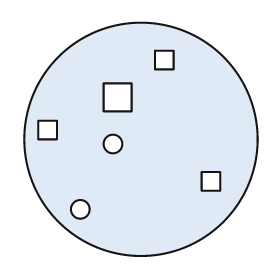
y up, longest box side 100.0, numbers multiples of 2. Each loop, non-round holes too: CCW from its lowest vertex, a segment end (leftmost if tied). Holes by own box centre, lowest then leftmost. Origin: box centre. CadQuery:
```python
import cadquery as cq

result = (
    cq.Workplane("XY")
    .moveTo(0.0, 0.0)
    .circle(50.0)
    .moveTo(-26.0, -30.0)
    .circle(4.0)
    .moveTo(26.0, -22.0)
    .lineTo(34.0, -22.0)
    .lineTo(34.0, -14.0)
    .lineTo(26.0, -14.0)
    .close()
    .moveTo(-12.0, -2.0)
    .circle(4.0)
    .moveTo(-44.0, 0.0)
    .lineTo(-36.0, 0.0)
    .lineTo(-36.0, 8.0)
    .lineTo(-44.0, 8.0)
    .close()
    .moveTo(-16.0, 12.0)
    .lineTo(-4.0, 12.0)
    .lineTo(-4.0, 24.0)
    .lineTo(-16.0, 24.0)
    .close()
    .moveTo(6.0, 30.0)
    .lineTo(14.0, 30.0)
    .lineTo(14.0, 38.0)
    .lineTo(6.0, 38.0)
    .close()
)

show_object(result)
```